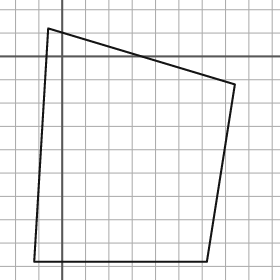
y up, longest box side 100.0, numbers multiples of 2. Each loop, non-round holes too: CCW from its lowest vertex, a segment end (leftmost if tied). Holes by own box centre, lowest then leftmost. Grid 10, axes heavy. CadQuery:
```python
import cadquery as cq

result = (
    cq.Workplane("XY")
    .moveTo(-12.0, -88.0)
    .lineTo(62.0, -88.0)
    .lineTo(74.0, -12.0)
    .lineTo(-6.0, 12.0)
    .close()
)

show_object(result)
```